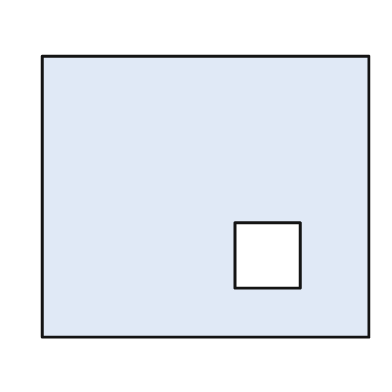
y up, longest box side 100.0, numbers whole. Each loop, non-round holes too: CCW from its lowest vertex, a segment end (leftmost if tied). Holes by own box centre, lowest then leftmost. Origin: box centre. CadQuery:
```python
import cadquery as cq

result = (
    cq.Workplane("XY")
    .moveTo(-50.0, -43.0)
    .lineTo(50.0, -43.0)
    .lineTo(50.0, 43.0)
    .lineTo(-50.0, 43.0)
    .close()
    .moveTo(9.0, -28.0)
    .lineTo(29.0, -28.0)
    .lineTo(29.0, -8.0)
    .lineTo(9.0, -8.0)
    .close()
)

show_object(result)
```